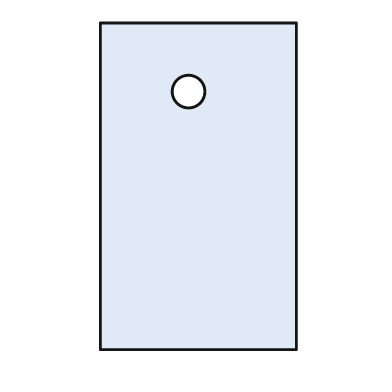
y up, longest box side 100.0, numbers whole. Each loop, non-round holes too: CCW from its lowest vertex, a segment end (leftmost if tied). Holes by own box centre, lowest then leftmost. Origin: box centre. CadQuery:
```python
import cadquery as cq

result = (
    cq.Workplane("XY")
    .moveTo(-30.0, -50.0)
    .lineTo(30.0, -50.0)
    .lineTo(30.0, 50.0)
    .lineTo(-30.0, 50.0)
    .close()
    .moveTo(-3.0, 29.0)
    .circle(5.0)
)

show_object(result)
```